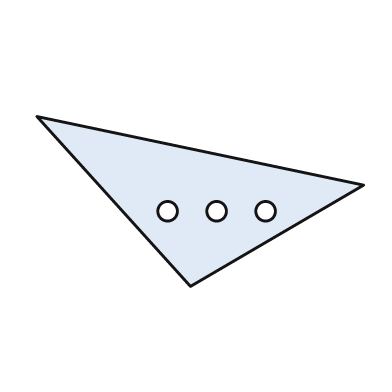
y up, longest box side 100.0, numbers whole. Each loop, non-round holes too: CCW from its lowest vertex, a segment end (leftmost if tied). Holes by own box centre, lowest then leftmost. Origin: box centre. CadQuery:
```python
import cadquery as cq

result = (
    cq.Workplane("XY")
    .moveTo(-3.0, -26.0)
    .lineTo(50.0, 5.0)
    .lineTo(-50.0, 26.0)
    .close()
    .moveTo(-10.0, -3.0)
    .circle(3.0)
    .moveTo(5.0, -3.0)
    .circle(3.0)
    .moveTo(20.0, -3.0)
    .circle(3.0)
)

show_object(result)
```